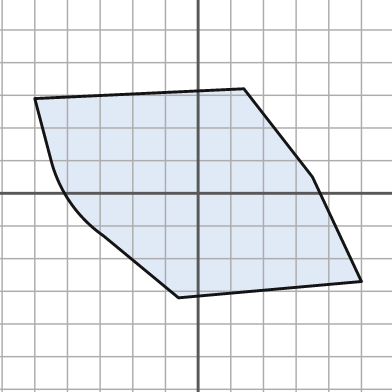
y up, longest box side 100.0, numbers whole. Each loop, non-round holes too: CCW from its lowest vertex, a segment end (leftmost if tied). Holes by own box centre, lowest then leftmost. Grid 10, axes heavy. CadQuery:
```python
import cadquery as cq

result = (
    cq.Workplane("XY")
    .moveTo(-6.0, -32.0)
    .lineTo(50.0, -27.0)
    .lineTo(35.0, 5.0)
    .lineTo(14.0, 32.0)
    .lineTo(-50.0, 29.0)
    .lineTo(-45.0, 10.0)
    .threePointArc((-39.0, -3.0), (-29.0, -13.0))
    .close()
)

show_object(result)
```